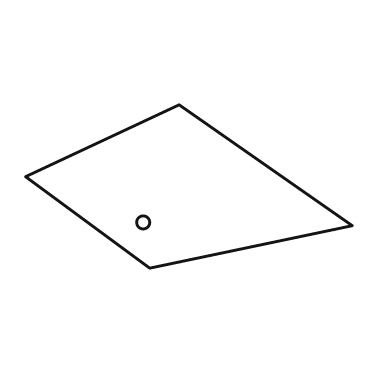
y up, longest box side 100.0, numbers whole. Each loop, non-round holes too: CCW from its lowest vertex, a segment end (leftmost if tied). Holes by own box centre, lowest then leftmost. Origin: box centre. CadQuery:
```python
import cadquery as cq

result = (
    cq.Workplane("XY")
    .moveTo(-12.0, -25.0)
    .lineTo(50.0, -12.0)
    .lineTo(-3.0, 25.0)
    .lineTo(-50.0, 3.0)
    .close()
    .moveTo(-14.0, -11.0)
    .circle(2.0)
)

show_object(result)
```